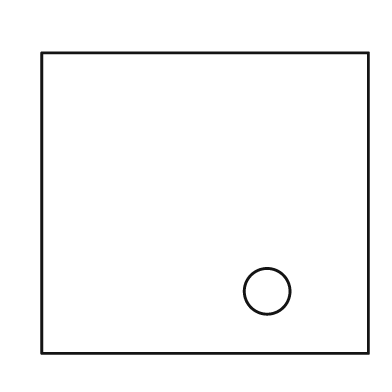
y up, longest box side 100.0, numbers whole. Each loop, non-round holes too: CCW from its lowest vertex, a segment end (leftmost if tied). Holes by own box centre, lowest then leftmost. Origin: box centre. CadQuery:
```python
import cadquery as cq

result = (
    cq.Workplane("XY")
    .moveTo(-50.0, -46.0)
    .lineTo(50.0, -46.0)
    .lineTo(50.0, 46.0)
    .lineTo(-50.0, 46.0)
    .close()
    .moveTo(19.0, -27.0)
    .circle(7.0)
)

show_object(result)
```